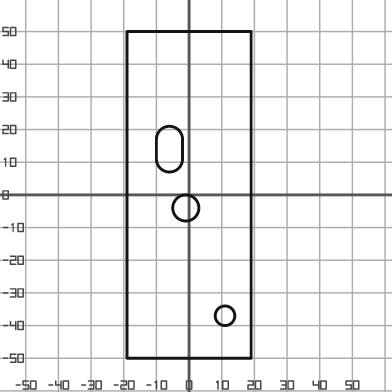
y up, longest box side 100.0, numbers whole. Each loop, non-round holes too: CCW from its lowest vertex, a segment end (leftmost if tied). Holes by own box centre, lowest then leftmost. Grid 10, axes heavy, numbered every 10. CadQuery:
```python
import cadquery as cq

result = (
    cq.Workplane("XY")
    .moveTo(-19.0, -50.0)
    .lineTo(19.0, -50.0)
    .lineTo(19.0, 50.0)
    .lineTo(-19.0, 50.0)
    .close()
    .moveTo(11.0, -37.0)
    .circle(3.0)
    .moveTo(-1.0, -4.0)
    .circle(4.0)
    .moveTo(-10.0, 11.0)
    .threePointArc((-6.0, 7.0), (-2.0, 11.0))
    .lineTo(-2.0, 17.0)
    .threePointArc((-6.0, 21.0), (-10.0, 17.0))
    .close()
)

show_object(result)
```